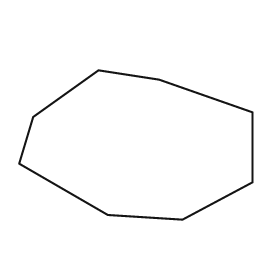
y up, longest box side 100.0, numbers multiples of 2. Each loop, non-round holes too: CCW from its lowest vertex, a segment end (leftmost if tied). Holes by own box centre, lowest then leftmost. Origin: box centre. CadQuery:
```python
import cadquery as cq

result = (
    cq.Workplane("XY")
    .moveTo(20.0, -32.0)
    .lineTo(50.0, -16.0)
    .lineTo(50.0, 14.0)
    .lineTo(10.0, 28.0)
    .lineTo(-16.0, 32.0)
    .lineTo(-44.0, 12.0)
    .lineTo(-50.0, -8.0)
    .lineTo(-12.0, -30.0)
    .close()
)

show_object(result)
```